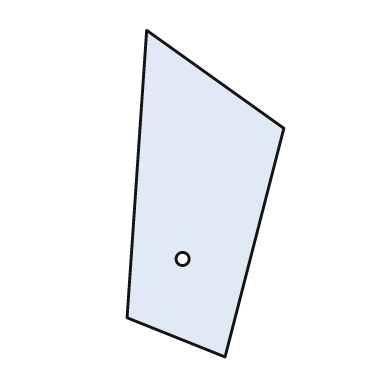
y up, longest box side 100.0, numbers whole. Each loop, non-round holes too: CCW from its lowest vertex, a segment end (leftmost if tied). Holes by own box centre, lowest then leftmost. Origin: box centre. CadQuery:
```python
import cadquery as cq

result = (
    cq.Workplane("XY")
    .moveTo(6.0, -50.0)
    .lineTo(24.0, 20.0)
    .lineTo(-18.0, 50.0)
    .lineTo(-24.0, -38.0)
    .close()
    .moveTo(-7.0, -20.0)
    .circle(2.0)
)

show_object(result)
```